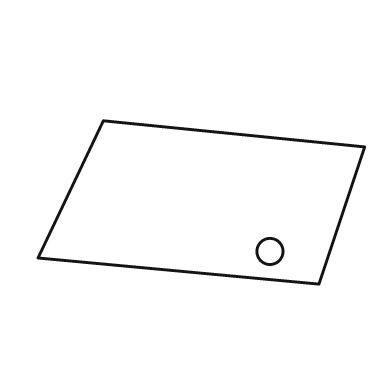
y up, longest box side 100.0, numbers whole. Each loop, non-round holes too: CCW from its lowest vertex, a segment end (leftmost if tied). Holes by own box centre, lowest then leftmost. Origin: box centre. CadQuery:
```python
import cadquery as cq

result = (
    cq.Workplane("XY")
    .moveTo(36.0, -25.0)
    .lineTo(50.0, 17.0)
    .lineTo(-30.0, 25.0)
    .lineTo(-50.0, -17.0)
    .close()
    .moveTo(21.0, -15.0)
    .circle(4.0)
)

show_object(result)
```